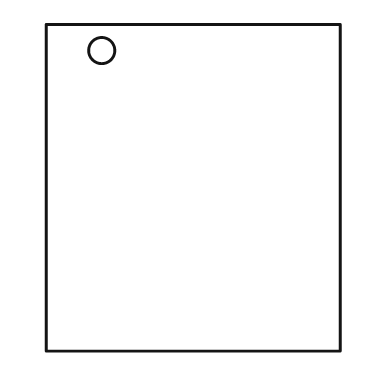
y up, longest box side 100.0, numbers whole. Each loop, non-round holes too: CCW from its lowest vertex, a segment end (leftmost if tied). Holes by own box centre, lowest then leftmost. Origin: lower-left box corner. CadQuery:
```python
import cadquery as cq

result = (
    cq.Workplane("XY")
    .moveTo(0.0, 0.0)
    .lineTo(90.0, 0.0)
    .lineTo(90.0, 100.0)
    .lineTo(0.0, 100.0)
    .close()
    .moveTo(17.0, 92.0)
    .circle(4.0)
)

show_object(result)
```